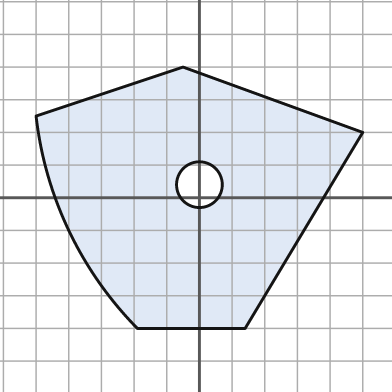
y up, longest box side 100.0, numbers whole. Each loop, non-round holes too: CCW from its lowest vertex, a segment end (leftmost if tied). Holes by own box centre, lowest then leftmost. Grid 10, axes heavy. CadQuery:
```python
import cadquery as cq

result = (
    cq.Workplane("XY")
    .moveTo(-19.0, -40.0)
    .lineTo(14.0, -40.0)
    .lineTo(50.0, 20.0)
    .lineTo(-5.0, 40.0)
    .lineTo(-50.0, 25.0)
    .threePointArc((-40.0, -10.0), (-19.0, -40.0))
    .close()
    .moveTo(0.0, 4.0)
    .circle(7.0)
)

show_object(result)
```